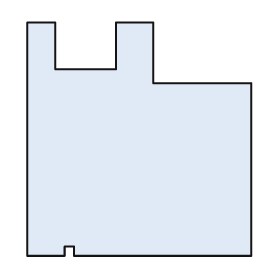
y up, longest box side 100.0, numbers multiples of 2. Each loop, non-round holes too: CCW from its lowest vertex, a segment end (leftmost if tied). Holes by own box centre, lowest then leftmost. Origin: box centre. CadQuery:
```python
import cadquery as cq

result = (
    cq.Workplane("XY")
    .moveTo(-48.0, -50.0)
    .lineTo(-32.0, -50.0)
    .lineTo(-32.0, -46.0)
    .lineTo(-28.0, -46.0)
    .lineTo(-28.0, -50.0)
    .lineTo(48.0, -50.0)
    .lineTo(48.0, 24.0)
    .lineTo(6.0, 24.0)
    .lineTo(6.0, 50.0)
    .lineTo(-10.0, 50.0)
    .lineTo(-10.0, 30.0)
    .lineTo(-36.0, 30.0)
    .lineTo(-36.0, 50.0)
    .lineTo(-48.0, 50.0)
    .close()
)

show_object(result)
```